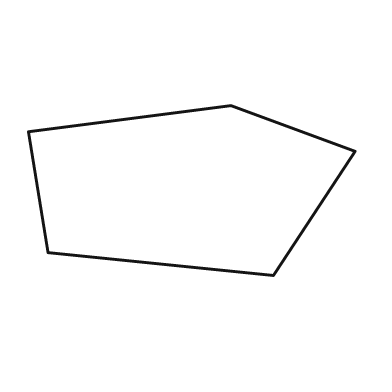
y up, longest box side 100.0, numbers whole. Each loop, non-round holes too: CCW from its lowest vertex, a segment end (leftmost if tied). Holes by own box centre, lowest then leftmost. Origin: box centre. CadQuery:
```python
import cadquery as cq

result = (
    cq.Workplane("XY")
    .moveTo(25.0, -26.0)
    .lineTo(50.0, 12.0)
    .lineTo(12.0, 26.0)
    .lineTo(-50.0, 18.0)
    .lineTo(-44.0, -19.0)
    .close()
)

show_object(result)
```